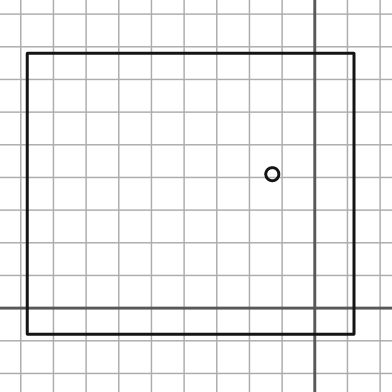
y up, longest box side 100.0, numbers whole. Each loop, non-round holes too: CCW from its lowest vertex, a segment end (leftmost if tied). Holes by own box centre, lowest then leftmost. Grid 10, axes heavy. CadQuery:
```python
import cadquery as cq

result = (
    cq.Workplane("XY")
    .moveTo(-88.0, -8.0)
    .lineTo(12.0, -8.0)
    .lineTo(12.0, 78.0)
    .lineTo(-88.0, 78.0)
    .close()
    .moveTo(-13.0, 41.0)
    .circle(2.0)
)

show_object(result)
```